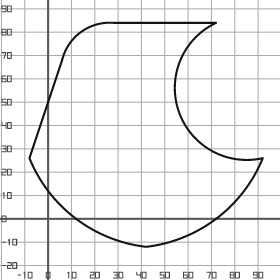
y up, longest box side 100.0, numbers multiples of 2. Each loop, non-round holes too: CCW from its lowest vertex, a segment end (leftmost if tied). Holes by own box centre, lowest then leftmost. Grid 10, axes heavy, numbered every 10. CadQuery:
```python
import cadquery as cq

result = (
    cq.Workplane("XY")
    .moveTo(42.0, -12.0)
    .threePointArc((72.0, 0.0), (92.0, 26.0))
    .threePointArc((56.0, 46.0), (72.0, 84.0))
    .lineTo(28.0, 84.0)
    .threePointArc((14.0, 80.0), (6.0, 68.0))
    .lineTo(-8.0, 26.0)
    .threePointArc((12.0, 0.0), (42.0, -12.0))
    .close()
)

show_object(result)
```